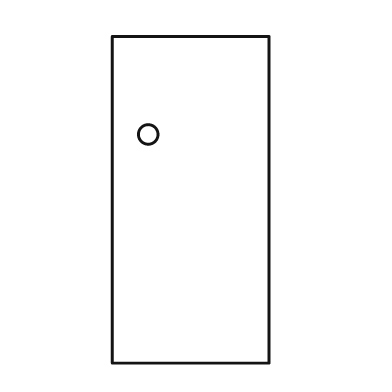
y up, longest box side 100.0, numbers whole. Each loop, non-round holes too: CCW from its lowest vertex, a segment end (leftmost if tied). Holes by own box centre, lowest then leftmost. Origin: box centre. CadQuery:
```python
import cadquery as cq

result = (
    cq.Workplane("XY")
    .moveTo(-24.0, -50.0)
    .lineTo(24.0, -50.0)
    .lineTo(24.0, 50.0)
    .lineTo(-24.0, 50.0)
    .close()
    .moveTo(-13.0, 20.0)
    .circle(3.0)
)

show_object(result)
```